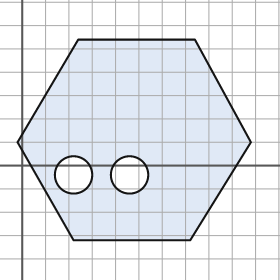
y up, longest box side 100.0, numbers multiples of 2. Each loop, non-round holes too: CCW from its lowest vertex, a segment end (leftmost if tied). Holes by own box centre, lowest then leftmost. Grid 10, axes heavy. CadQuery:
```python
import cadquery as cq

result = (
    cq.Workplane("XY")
    .moveTo(22.0, -32.0)
    .lineTo(72.0, -32.0)
    .lineTo(98.0, 10.0)
    .lineTo(74.0, 54.0)
    .lineTo(24.0, 54.0)
    .lineTo(-2.0, 10.0)
    .close()
    .moveTo(22.0, -4.0)
    .circle(8.0)
    .moveTo(46.0, -4.0)
    .circle(8.0)
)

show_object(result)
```